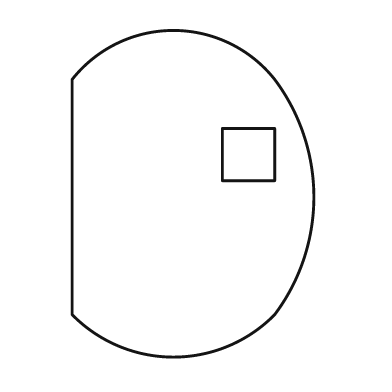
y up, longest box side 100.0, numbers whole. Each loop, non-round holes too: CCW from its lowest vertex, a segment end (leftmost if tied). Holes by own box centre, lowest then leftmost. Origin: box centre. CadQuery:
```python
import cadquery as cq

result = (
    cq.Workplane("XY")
    .moveTo(-37.0, -37.0)
    .threePointArc((-6.0, -50.0), (25.0, -37.0))
    .threePointArc((37.0, -1.0), (25.0, 35.0))
    .threePointArc((-6.0, 50.0), (-37.0, 35.0))
    .close()
    .moveTo(9.0, 4.0)
    .lineTo(25.0, 4.0)
    .lineTo(25.0, 20.0)
    .lineTo(9.0, 20.0)
    .close()
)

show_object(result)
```